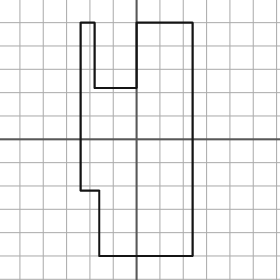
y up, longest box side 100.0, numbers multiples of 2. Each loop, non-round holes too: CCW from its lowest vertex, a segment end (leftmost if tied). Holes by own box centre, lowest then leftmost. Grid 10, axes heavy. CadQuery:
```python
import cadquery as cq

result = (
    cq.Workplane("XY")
    .moveTo(-16.0, -50.0)
    .lineTo(24.0, -50.0)
    .lineTo(24.0, 50.0)
    .lineTo(0.0, 50.0)
    .lineTo(0.0, 22.0)
    .lineTo(-18.0, 22.0)
    .lineTo(-18.0, 50.0)
    .lineTo(-24.0, 50.0)
    .lineTo(-24.0, -22.0)
    .lineTo(-16.0, -22.0)
    .close()
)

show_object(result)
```